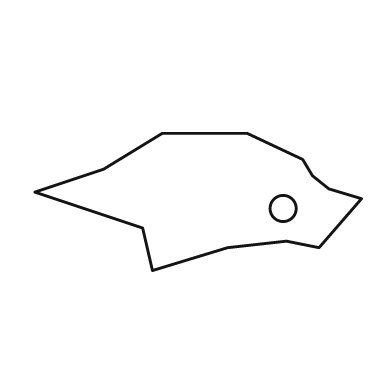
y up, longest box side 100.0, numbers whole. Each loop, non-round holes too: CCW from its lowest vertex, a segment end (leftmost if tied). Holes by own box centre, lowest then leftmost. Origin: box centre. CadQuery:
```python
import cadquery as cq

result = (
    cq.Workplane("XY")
    .moveTo(-14.0, -21.0)
    .lineTo(9.0, -14.0)
    .lineTo(27.0, -12.0)
    .lineTo(37.0, -14.0)
    .lineTo(50.0, 1.0)
    .lineTo(40.0, 4.0)
    .lineTo(35.0, 8.0)
    .lineTo(32.0, 13.0)
    .lineTo(15.0, 21.0)
    .lineTo(-11.0, 21.0)
    .lineTo(-29.0, 10.0)
    .lineTo(-50.0, 3.0)
    .lineTo(-17.0, -8.0)
    .close()
    .moveTo(26.0, -2.0)
    .circle(4.0)
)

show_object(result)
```